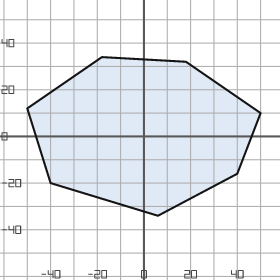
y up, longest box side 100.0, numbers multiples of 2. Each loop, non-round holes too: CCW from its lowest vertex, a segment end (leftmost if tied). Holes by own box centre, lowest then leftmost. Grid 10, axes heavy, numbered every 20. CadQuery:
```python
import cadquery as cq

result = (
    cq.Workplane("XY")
    .moveTo(6.0, -34.0)
    .lineTo(40.0, -16.0)
    .lineTo(50.0, 10.0)
    .lineTo(18.0, 32.0)
    .lineTo(-18.0, 34.0)
    .lineTo(-50.0, 12.0)
    .lineTo(-40.0, -20.0)
    .close()
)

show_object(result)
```